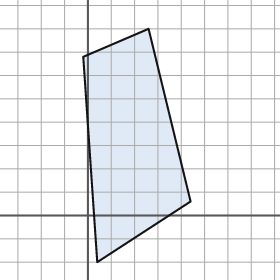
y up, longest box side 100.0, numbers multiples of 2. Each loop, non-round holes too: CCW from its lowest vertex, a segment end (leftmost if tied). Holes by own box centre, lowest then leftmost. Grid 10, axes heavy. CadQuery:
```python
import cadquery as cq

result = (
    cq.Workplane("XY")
    .moveTo(4.0, -20.0)
    .lineTo(44.0, 6.0)
    .lineTo(26.0, 80.0)
    .lineTo(-2.0, 68.0)
    .close()
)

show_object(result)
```